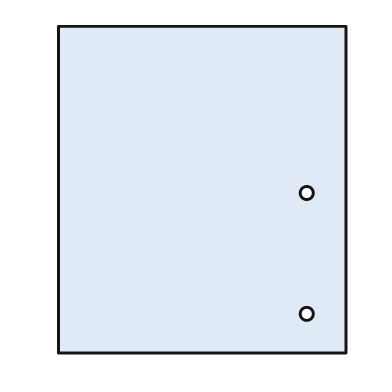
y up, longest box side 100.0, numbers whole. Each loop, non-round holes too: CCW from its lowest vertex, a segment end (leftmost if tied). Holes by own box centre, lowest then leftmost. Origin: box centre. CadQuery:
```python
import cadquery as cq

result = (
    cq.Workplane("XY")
    .moveTo(-44.0, -50.0)
    .lineTo(44.0, -50.0)
    .lineTo(44.0, 50.0)
    .lineTo(-44.0, 50.0)
    .close()
    .moveTo(32.0, -38.0)
    .circle(2.0)
    .moveTo(32.0, -1.0)
    .circle(2.0)
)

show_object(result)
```